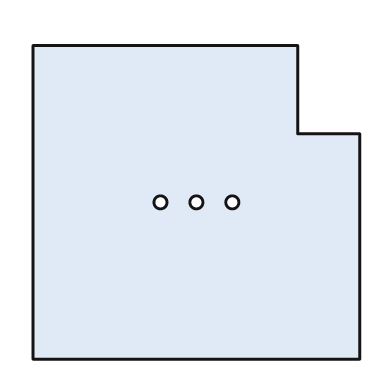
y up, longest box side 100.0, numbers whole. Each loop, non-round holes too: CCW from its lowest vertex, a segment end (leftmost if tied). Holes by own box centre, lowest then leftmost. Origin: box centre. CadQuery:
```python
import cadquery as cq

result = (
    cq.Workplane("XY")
    .moveTo(-50.0, -48.0)
    .lineTo(50.0, -48.0)
    .lineTo(50.0, 21.0)
    .lineTo(31.0, 21.0)
    .lineTo(31.0, 48.0)
    .lineTo(-50.0, 48.0)
    .close()
    .moveTo(-11.0, 0.0)
    .circle(2.0)
    .moveTo(0.0, 0.0)
    .circle(2.0)
    .moveTo(11.0, 0.0)
    .circle(2.0)
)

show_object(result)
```